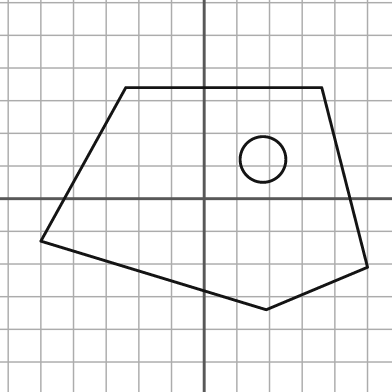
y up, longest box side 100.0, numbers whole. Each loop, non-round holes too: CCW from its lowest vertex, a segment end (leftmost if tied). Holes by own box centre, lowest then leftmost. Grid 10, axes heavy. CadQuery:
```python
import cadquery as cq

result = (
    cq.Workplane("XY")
    .moveTo(19.0, -34.0)
    .lineTo(50.0, -21.0)
    .lineTo(36.0, 34.0)
    .lineTo(-24.0, 34.0)
    .lineTo(-50.0, -13.0)
    .close()
    .moveTo(18.0, 12.0)
    .circle(7.0)
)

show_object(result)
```